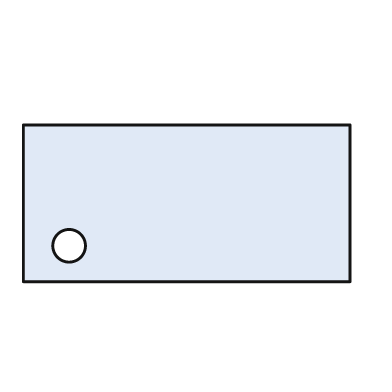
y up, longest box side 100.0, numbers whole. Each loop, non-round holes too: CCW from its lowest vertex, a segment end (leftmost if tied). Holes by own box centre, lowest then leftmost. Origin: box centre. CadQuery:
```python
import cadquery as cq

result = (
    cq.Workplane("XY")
    .moveTo(-50.0, -24.0)
    .lineTo(50.0, -24.0)
    .lineTo(50.0, 24.0)
    .lineTo(-50.0, 24.0)
    .close()
    .moveTo(-36.0, -13.0)
    .circle(5.0)
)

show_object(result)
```